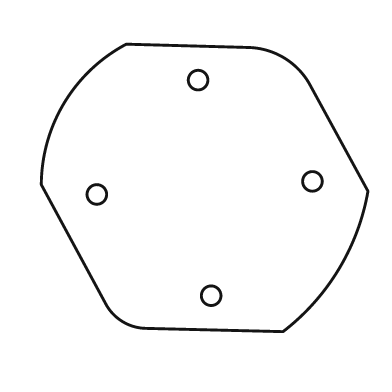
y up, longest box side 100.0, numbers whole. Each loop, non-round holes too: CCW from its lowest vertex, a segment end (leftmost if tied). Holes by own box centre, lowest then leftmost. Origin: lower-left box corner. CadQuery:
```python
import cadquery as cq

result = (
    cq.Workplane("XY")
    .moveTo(74.0, 0.0)
    .threePointArc((91.0, 19.0), (100.0, 43.0))
    .lineTo(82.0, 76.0)
    .threePointArc((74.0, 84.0), (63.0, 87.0))
    .lineTo(26.0, 88.0)
    .threePointArc((7.0, 70.0), (0.0, 45.0))
    .lineTo(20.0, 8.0)
    .threePointArc((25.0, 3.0), (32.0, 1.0))
    .close()
    .moveTo(52.0, 11.0)
    .circle(3.0)
    .moveTo(17.0, 42.0)
    .circle(3.0)
    .moveTo(83.0, 46.0)
    .circle(3.0)
    .moveTo(48.0, 77.0)
    .circle(3.0)
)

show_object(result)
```